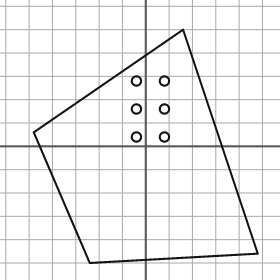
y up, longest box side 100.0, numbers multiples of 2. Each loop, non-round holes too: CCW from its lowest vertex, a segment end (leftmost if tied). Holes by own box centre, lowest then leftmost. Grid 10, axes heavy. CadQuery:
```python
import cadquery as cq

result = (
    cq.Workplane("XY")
    .moveTo(-24.0, -50.0)
    .lineTo(48.0, -46.0)
    .lineTo(16.0, 50.0)
    .lineTo(-48.0, 6.0)
    .close()
    .moveTo(-4.0, 4.0)
    .circle(2.0)
    .moveTo(8.0, 4.0)
    .circle(2.0)
    .moveTo(-4.0, 16.0)
    .circle(2.0)
    .moveTo(8.0, 16.0)
    .circle(2.0)
    .moveTo(-4.0, 28.0)
    .circle(2.0)
    .moveTo(8.0, 28.0)
    .circle(2.0)
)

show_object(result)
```